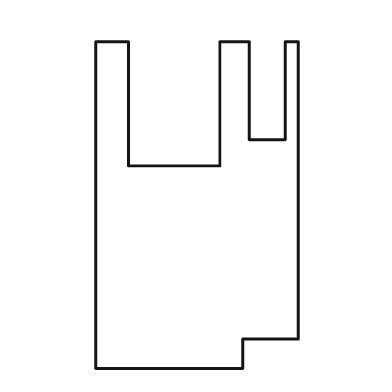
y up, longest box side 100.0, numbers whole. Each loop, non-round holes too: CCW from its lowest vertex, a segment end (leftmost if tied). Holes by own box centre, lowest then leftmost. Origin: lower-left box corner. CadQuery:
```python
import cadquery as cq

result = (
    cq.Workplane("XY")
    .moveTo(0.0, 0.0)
    .lineTo(45.0, 0.0)
    .lineTo(45.0, 9.0)
    .lineTo(62.0, 9.0)
    .lineTo(62.0, 100.0)
    .lineTo(58.0, 100.0)
    .lineTo(58.0, 70.0)
    .lineTo(47.0, 70.0)
    .lineTo(47.0, 100.0)
    .lineTo(38.0, 100.0)
    .lineTo(38.0, 62.0)
    .lineTo(10.0, 62.0)
    .lineTo(10.0, 100.0)
    .lineTo(0.0, 100.0)
    .close()
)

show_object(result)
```